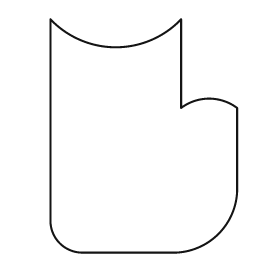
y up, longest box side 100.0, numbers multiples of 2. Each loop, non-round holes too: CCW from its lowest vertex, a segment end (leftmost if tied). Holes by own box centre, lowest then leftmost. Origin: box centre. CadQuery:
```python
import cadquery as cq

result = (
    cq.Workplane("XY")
    .moveTo(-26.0, -50.0)
    .lineTo(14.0, -50.0)
    .threePointArc((32.0, -42.0), (40.0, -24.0))
    .lineTo(40.0, 12.0)
    .threePointArc((28.0, 16.0), (16.0, 12.0))
    .lineTo(16.0, 50.0)
    .threePointArc((-12.0, 38.0), (-40.0, 50.0))
    .lineTo(-40.0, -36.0)
    .threePointArc((-36.0, -46.0), (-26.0, -50.0))
    .close()
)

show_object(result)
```